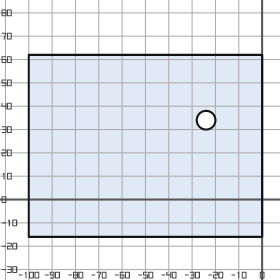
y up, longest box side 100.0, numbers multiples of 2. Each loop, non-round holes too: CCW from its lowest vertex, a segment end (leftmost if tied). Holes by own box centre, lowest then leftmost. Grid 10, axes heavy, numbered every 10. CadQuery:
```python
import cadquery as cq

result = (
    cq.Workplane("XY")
    .moveTo(-100.0, -16.0)
    .lineTo(0.0, -16.0)
    .lineTo(0.0, 62.0)
    .lineTo(-100.0, 62.0)
    .close()
    .moveTo(-24.0, 34.0)
    .circle(4.0)
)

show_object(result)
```